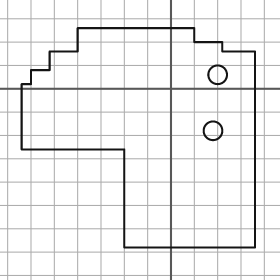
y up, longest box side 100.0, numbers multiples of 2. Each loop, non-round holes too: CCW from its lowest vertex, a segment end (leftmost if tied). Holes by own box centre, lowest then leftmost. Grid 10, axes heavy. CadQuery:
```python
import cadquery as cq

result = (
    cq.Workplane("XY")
    .moveTo(-20.0, -68.0)
    .lineTo(36.0, -68.0)
    .lineTo(36.0, 16.0)
    .lineTo(22.0, 16.0)
    .lineTo(22.0, 20.0)
    .lineTo(10.0, 20.0)
    .lineTo(10.0, 26.0)
    .lineTo(-40.0, 26.0)
    .lineTo(-40.0, 16.0)
    .lineTo(-52.0, 16.0)
    .lineTo(-52.0, 8.0)
    .lineTo(-60.0, 8.0)
    .lineTo(-60.0, 2.0)
    .lineTo(-64.0, 2.0)
    .lineTo(-64.0, -26.0)
    .lineTo(-20.0, -26.0)
    .close()
    .moveTo(18.0, -18.0)
    .circle(4.0)
    .moveTo(20.0, 6.0)
    .circle(4.0)
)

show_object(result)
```